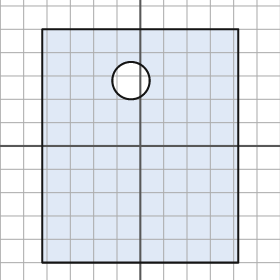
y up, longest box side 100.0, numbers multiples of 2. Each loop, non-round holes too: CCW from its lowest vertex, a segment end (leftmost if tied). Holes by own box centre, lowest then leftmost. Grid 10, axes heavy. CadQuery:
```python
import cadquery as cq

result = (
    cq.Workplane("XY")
    .moveTo(-42.0, -50.0)
    .lineTo(42.0, -50.0)
    .lineTo(42.0, 50.0)
    .lineTo(-42.0, 50.0)
    .close()
    .moveTo(-4.0, 28.0)
    .circle(8.0)
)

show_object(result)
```